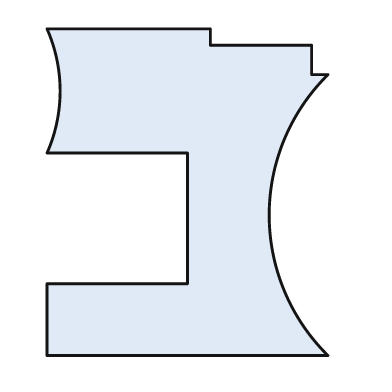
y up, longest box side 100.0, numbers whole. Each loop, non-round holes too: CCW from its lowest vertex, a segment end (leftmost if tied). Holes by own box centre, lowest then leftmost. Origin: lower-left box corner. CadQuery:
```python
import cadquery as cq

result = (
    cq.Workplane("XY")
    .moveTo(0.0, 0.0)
    .lineTo(86.0, 0.0)
    .threePointArc((68.0, 43.0), (86.0, 86.0))
    .lineTo(81.0, 86.0)
    .lineTo(81.0, 95.0)
    .lineTo(50.0, 95.0)
    .lineTo(50.0, 100.0)
    .lineTo(0.0, 100.0)
    .threePointArc((4.0, 81.0), (0.0, 62.0))
    .lineTo(43.0, 62.0)
    .lineTo(43.0, 22.0)
    .lineTo(0.0, 22.0)
    .close()
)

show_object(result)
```